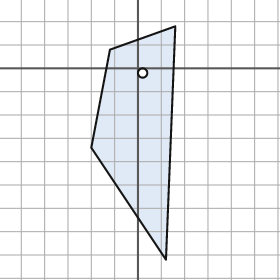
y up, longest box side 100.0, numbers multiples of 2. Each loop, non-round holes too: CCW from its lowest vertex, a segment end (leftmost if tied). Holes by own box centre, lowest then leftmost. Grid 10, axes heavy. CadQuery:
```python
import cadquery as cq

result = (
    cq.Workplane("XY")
    .moveTo(12.0, -82.0)
    .lineTo(16.0, 18.0)
    .lineTo(-12.0, 8.0)
    .lineTo(-20.0, -34.0)
    .close()
    .moveTo(2.0, -2.0)
    .circle(2.0)
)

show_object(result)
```